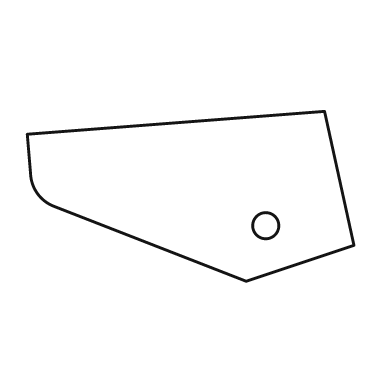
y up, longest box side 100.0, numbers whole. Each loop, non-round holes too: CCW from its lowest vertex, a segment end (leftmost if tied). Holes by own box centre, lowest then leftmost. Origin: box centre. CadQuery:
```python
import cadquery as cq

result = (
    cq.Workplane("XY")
    .moveTo(17.0, -26.0)
    .lineTo(50.0, -15.0)
    .lineTo(41.0, 26.0)
    .lineTo(-50.0, 19.0)
    .lineTo(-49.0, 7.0)
    .threePointArc((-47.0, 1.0), (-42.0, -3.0))
    .close()
    .moveTo(23.0, -9.0)
    .circle(4.0)
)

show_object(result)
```